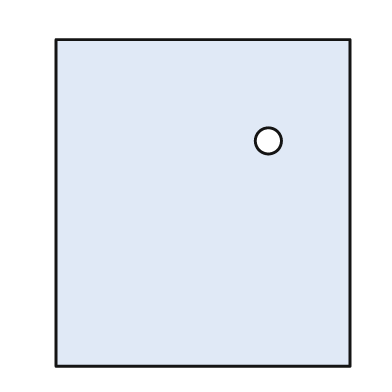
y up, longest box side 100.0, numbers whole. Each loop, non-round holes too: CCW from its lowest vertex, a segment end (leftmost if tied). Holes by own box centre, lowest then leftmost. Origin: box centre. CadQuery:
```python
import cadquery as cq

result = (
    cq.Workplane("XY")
    .moveTo(-45.0, -50.0)
    .lineTo(45.0, -50.0)
    .lineTo(45.0, 50.0)
    .lineTo(-45.0, 50.0)
    .close()
    .moveTo(20.0, 19.0)
    .circle(4.0)
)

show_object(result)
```